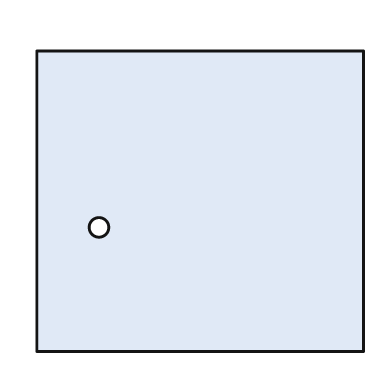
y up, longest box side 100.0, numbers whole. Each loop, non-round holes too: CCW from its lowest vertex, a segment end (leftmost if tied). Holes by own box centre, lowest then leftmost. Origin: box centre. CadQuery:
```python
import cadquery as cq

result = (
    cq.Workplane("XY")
    .moveTo(-50.0, -46.0)
    .lineTo(50.0, -46.0)
    .lineTo(50.0, 46.0)
    .lineTo(-50.0, 46.0)
    .close()
    .moveTo(-31.0, -8.0)
    .circle(3.0)
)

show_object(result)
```